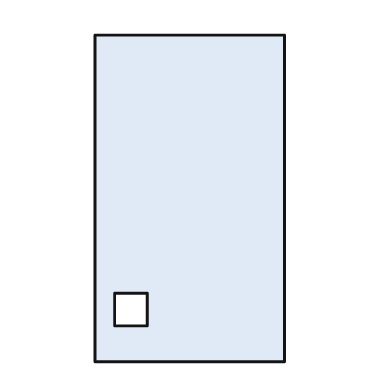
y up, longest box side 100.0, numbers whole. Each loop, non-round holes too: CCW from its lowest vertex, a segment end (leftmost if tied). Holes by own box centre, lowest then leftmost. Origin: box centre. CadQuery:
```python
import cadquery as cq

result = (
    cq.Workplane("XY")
    .moveTo(-29.0, -50.0)
    .lineTo(29.0, -50.0)
    .lineTo(29.0, 50.0)
    .lineTo(-29.0, 50.0)
    .close()
    .moveTo(-23.0, -39.0)
    .lineTo(-13.0, -39.0)
    .lineTo(-13.0, -29.0)
    .lineTo(-23.0, -29.0)
    .close()
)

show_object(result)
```